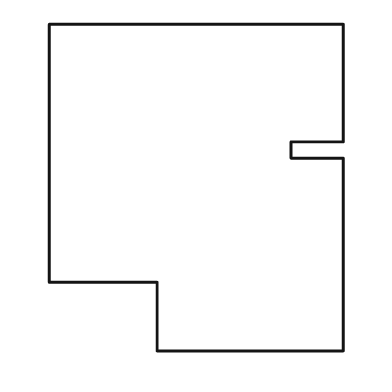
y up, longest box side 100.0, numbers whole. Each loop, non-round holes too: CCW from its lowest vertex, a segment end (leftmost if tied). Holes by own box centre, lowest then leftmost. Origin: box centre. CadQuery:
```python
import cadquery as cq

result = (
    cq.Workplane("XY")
    .moveTo(-12.0, -50.0)
    .lineTo(45.0, -50.0)
    .lineTo(45.0, 9.0)
    .lineTo(29.0, 9.0)
    .lineTo(29.0, 14.0)
    .lineTo(45.0, 14.0)
    .lineTo(45.0, 50.0)
    .lineTo(-45.0, 50.0)
    .lineTo(-45.0, -29.0)
    .lineTo(-12.0, -29.0)
    .close()
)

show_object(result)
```